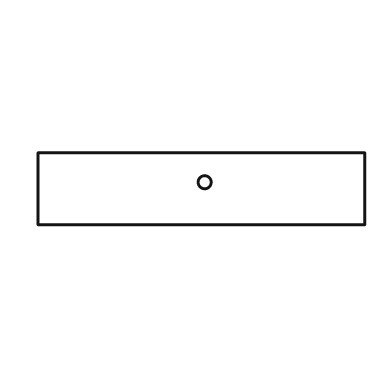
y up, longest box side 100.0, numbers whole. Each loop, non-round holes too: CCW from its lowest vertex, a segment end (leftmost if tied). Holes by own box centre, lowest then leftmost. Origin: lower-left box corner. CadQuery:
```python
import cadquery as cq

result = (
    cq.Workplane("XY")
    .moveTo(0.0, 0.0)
    .lineTo(100.0, 0.0)
    .lineTo(100.0, 22.0)
    .lineTo(0.0, 22.0)
    .close()
    .moveTo(51.0, 13.0)
    .circle(2.0)
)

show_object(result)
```